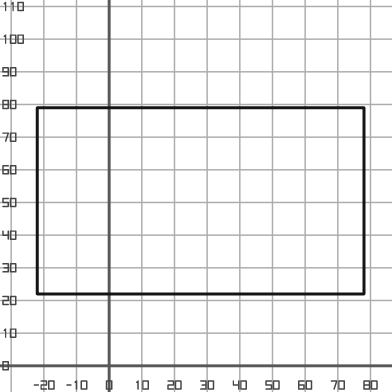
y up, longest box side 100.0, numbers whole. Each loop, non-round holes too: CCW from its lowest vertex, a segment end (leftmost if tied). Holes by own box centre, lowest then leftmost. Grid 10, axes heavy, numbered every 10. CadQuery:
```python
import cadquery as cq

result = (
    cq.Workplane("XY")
    .moveTo(-22.0, 22.0)
    .lineTo(78.0, 22.0)
    .lineTo(78.0, 79.0)
    .lineTo(-22.0, 79.0)
    .close()
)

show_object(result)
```